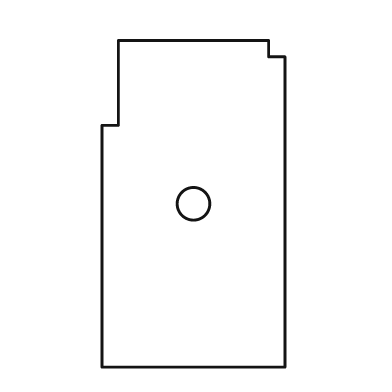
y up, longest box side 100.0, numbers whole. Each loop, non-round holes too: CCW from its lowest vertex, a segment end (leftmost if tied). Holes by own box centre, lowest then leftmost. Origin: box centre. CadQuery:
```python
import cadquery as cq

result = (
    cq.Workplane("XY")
    .moveTo(-28.0, -50.0)
    .lineTo(28.0, -50.0)
    .lineTo(28.0, 45.0)
    .lineTo(23.0, 45.0)
    .lineTo(23.0, 50.0)
    .lineTo(-23.0, 50.0)
    .lineTo(-23.0, 24.0)
    .lineTo(-28.0, 24.0)
    .close()
    .moveTo(0.0, 0.0)
    .circle(5.0)
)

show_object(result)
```